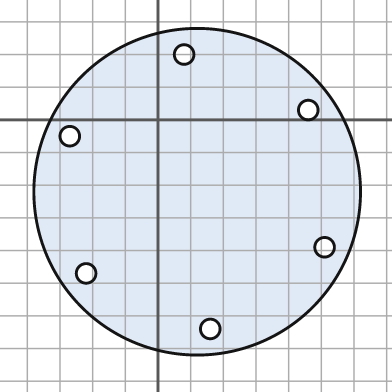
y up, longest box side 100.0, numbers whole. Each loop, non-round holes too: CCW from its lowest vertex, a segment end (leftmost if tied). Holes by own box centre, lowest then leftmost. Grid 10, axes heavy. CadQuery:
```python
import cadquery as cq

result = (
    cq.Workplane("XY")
    .moveTo(12.0, -22.0)
    .circle(50.0)
    .moveTo(16.0, -64.0)
    .circle(3.0)
    .moveTo(-22.0, -47.0)
    .circle(3.0)
    .moveTo(51.0, -39.0)
    .circle(3.0)
    .moveTo(-27.0, -5.0)
    .circle(3.0)
    .moveTo(46.0, 3.0)
    .circle(3.0)
    .moveTo(8.0, 20.0)
    .circle(3.0)
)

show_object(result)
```